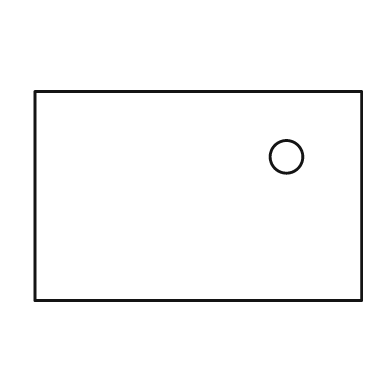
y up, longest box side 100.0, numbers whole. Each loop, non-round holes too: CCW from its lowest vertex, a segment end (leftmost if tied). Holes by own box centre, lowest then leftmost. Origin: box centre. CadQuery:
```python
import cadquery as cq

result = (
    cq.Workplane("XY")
    .moveTo(-50.0, -32.0)
    .lineTo(50.0, -32.0)
    .lineTo(50.0, 32.0)
    .lineTo(-50.0, 32.0)
    .close()
    .moveTo(27.0, 12.0)
    .circle(5.0)
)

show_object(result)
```